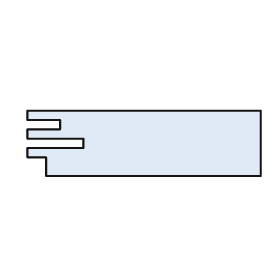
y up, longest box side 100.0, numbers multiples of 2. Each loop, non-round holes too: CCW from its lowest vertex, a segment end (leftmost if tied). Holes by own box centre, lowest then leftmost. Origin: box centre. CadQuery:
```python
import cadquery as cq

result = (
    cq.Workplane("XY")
    .moveTo(-42.0, -14.0)
    .lineTo(50.0, -14.0)
    .lineTo(50.0, 14.0)
    .lineTo(-50.0, 14.0)
    .lineTo(-50.0, 10.0)
    .lineTo(-36.0, 10.0)
    .lineTo(-36.0, 6.0)
    .lineTo(-50.0, 6.0)
    .lineTo(-50.0, 2.0)
    .lineTo(-26.0, 2.0)
    .lineTo(-26.0, -2.0)
    .lineTo(-50.0, -2.0)
    .lineTo(-50.0, -6.0)
    .lineTo(-42.0, -6.0)
    .close()
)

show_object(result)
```